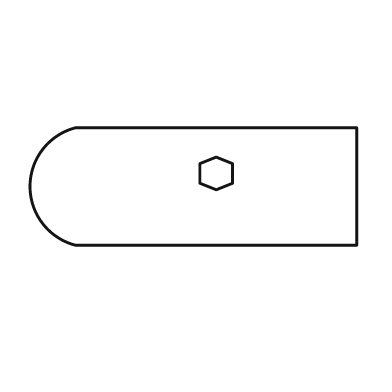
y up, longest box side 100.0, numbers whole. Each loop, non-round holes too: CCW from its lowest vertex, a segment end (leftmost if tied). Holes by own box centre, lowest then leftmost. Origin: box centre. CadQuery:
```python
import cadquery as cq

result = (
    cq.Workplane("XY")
    .moveTo(-36.0, -18.0)
    .lineTo(50.0, -18.0)
    .lineTo(50.0, 18.0)
    .lineTo(-36.0, 18.0)
    .threePointArc((-50.0, 0.0), (-36.0, -18.0))
    .close()
    .moveTo(7.0, -1.0)
    .lineTo(12.0, 1.0)
    .lineTo(12.0, 7.0)
    .lineTo(7.0, 9.0)
    .lineTo(2.0, 7.0)
    .lineTo(2.0, 1.0)
    .close()
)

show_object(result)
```